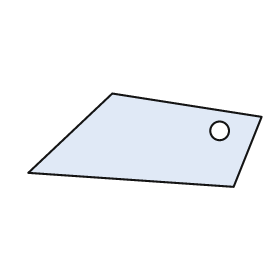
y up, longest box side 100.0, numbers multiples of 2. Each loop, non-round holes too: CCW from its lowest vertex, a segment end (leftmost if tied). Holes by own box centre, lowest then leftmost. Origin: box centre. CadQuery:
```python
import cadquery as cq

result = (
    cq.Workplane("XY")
    .moveTo(38.0, -20.0)
    .lineTo(50.0, 10.0)
    .lineTo(-14.0, 20.0)
    .lineTo(-50.0, -14.0)
    .close()
    .moveTo(32.0, 4.0)
    .circle(4.0)
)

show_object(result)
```